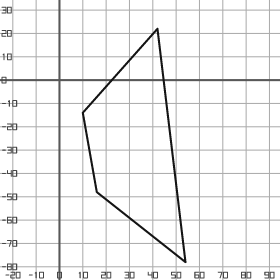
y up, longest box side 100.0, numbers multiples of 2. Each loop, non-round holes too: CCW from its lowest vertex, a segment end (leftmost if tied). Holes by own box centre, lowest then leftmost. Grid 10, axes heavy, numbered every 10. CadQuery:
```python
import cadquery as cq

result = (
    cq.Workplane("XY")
    .moveTo(54.0, -78.0)
    .lineTo(42.0, 22.0)
    .lineTo(10.0, -14.0)
    .lineTo(16.0, -48.0)
    .close()
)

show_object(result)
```